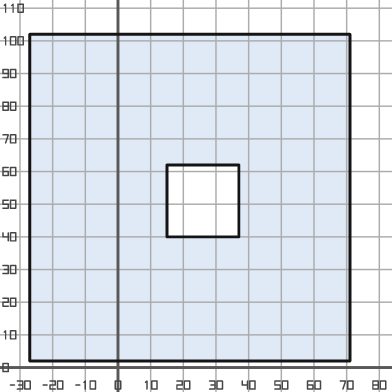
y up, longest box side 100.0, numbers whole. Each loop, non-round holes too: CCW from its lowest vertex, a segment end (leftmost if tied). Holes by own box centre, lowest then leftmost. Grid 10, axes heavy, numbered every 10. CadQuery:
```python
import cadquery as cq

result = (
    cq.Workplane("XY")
    .moveTo(-27.0, 2.0)
    .lineTo(71.0, 2.0)
    .lineTo(71.0, 102.0)
    .lineTo(-27.0, 102.0)
    .close()
    .moveTo(15.0, 40.0)
    .lineTo(37.0, 40.0)
    .lineTo(37.0, 62.0)
    .lineTo(15.0, 62.0)
    .close()
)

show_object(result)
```